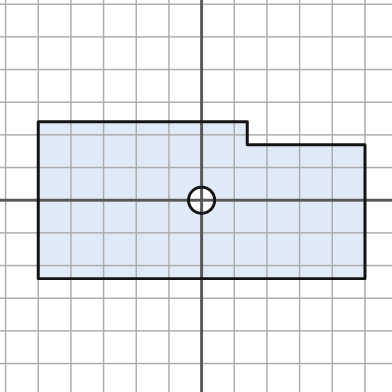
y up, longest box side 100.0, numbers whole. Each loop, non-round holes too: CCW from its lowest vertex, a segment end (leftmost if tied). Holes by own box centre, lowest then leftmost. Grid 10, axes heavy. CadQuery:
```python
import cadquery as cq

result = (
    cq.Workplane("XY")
    .moveTo(-50.0, -24.0)
    .lineTo(50.0, -24.0)
    .lineTo(50.0, 17.0)
    .lineTo(14.0, 17.0)
    .lineTo(14.0, 24.0)
    .lineTo(-50.0, 24.0)
    .close()
    .moveTo(0.0, 0.0)
    .circle(4.0)
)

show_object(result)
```